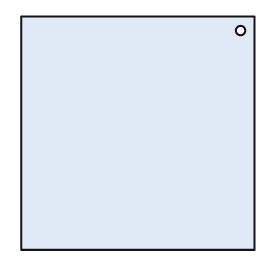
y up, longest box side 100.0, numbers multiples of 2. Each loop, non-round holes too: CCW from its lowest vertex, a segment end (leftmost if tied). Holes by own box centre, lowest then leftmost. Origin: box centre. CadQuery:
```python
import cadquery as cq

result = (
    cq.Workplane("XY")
    .moveTo(-50.0, -50.0)
    .lineTo(50.0, -50.0)
    .lineTo(50.0, 50.0)
    .lineTo(-50.0, 50.0)
    .close()
    .moveTo(44.0, 44.0)
    .circle(2.0)
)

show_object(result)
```